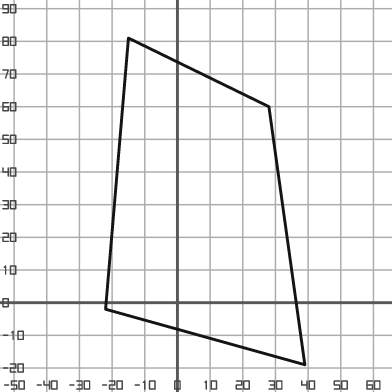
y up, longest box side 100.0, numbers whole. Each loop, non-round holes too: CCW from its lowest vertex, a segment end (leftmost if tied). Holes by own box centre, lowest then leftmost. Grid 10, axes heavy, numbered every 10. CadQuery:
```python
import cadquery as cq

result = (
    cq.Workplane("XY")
    .moveTo(39.0, -19.0)
    .lineTo(28.0, 60.0)
    .lineTo(-15.0, 81.0)
    .lineTo(-22.0, -2.0)
    .close()
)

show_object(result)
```